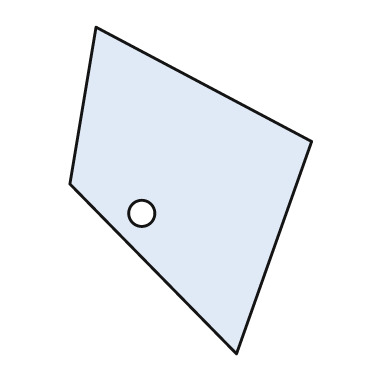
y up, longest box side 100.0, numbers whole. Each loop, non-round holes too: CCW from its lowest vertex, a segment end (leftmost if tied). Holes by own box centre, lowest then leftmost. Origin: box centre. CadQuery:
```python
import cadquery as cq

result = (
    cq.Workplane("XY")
    .moveTo(14.0, -50.0)
    .lineTo(37.0, 15.0)
    .lineTo(-29.0, 50.0)
    .lineTo(-37.0, 2.0)
    .close()
    .moveTo(-15.0, -7.0)
    .circle(4.0)
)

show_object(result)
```